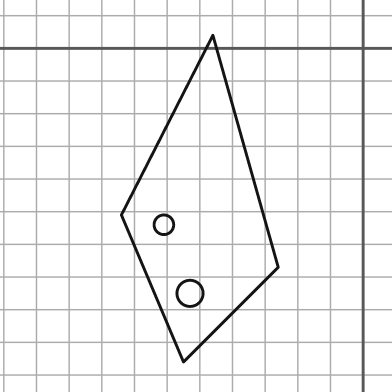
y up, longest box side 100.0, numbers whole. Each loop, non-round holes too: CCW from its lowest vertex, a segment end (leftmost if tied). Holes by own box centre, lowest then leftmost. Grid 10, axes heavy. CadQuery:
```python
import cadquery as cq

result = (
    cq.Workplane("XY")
    .moveTo(-55.0, -96.0)
    .lineTo(-26.0, -67.0)
    .lineTo(-46.0, 4.0)
    .lineTo(-74.0, -51.0)
    .close()
    .moveTo(-53.0, -75.0)
    .circle(4.0)
    .moveTo(-61.0, -54.0)
    .circle(3.0)
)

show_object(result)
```